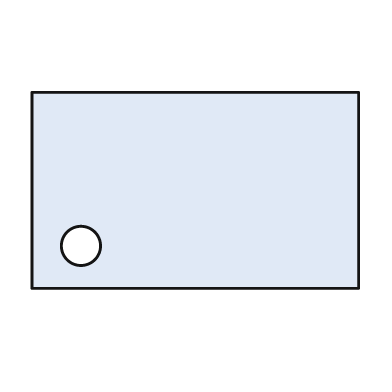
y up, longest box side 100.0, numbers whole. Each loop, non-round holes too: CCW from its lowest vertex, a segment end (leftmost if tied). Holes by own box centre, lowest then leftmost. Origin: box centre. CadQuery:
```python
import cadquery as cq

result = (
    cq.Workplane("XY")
    .moveTo(-50.0, -30.0)
    .lineTo(50.0, -30.0)
    .lineTo(50.0, 30.0)
    .lineTo(-50.0, 30.0)
    .close()
    .moveTo(-35.0, -17.0)
    .circle(6.0)
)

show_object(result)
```